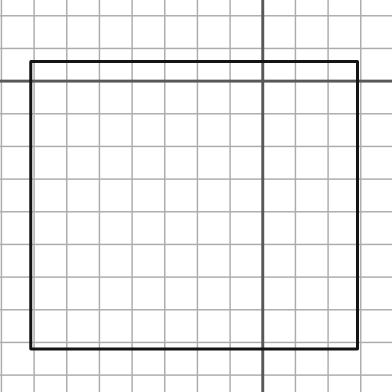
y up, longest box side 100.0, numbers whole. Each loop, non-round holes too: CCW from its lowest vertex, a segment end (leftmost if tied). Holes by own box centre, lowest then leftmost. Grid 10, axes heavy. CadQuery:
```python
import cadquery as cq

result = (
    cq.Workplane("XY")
    .moveTo(-71.0, -82.0)
    .lineTo(29.0, -82.0)
    .lineTo(29.0, 6.0)
    .lineTo(-71.0, 6.0)
    .close()
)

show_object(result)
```